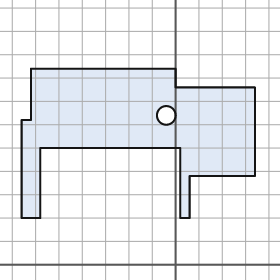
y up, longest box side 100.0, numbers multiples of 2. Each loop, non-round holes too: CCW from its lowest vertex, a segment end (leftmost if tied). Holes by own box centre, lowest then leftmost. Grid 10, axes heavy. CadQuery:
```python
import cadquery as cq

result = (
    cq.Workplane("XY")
    .moveTo(-66.0, 20.0)
    .lineTo(-58.0, 20.0)
    .lineTo(-58.0, 50.0)
    .lineTo(2.0, 50.0)
    .lineTo(2.0, 20.0)
    .lineTo(6.0, 20.0)
    .lineTo(6.0, 38.0)
    .lineTo(34.0, 38.0)
    .lineTo(34.0, 76.0)
    .lineTo(0.0, 76.0)
    .lineTo(0.0, 84.0)
    .lineTo(-62.0, 84.0)
    .lineTo(-62.0, 62.0)
    .lineTo(-66.0, 62.0)
    .close()
    .moveTo(-4.0, 64.0)
    .circle(4.0)
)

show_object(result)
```